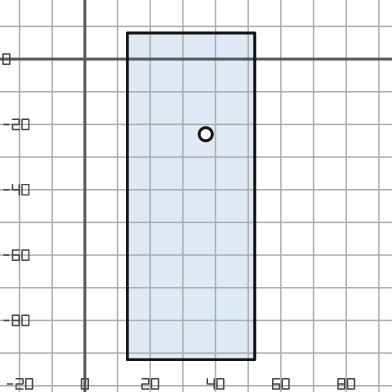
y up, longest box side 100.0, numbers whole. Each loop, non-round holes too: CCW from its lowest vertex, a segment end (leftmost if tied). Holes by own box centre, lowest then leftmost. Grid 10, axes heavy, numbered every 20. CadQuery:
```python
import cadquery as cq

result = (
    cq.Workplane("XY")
    .moveTo(13.0, -92.0)
    .lineTo(52.0, -92.0)
    .lineTo(52.0, 8.0)
    .lineTo(13.0, 8.0)
    .close()
    .moveTo(37.0, -23.0)
    .circle(2.0)
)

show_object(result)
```